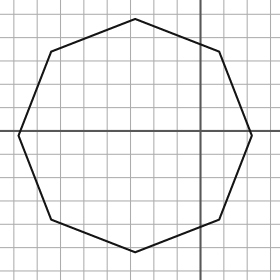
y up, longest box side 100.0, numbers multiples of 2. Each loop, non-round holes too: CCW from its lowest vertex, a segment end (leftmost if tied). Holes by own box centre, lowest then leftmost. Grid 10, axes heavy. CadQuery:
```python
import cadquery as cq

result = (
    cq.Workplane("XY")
    .moveTo(-28.0, -52.0)
    .lineTo(8.0, -38.0)
    .lineTo(22.0, -2.0)
    .lineTo(8.0, 34.0)
    .lineTo(-28.0, 48.0)
    .lineTo(-64.0, 34.0)
    .lineTo(-78.0, -2.0)
    .lineTo(-64.0, -38.0)
    .close()
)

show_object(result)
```